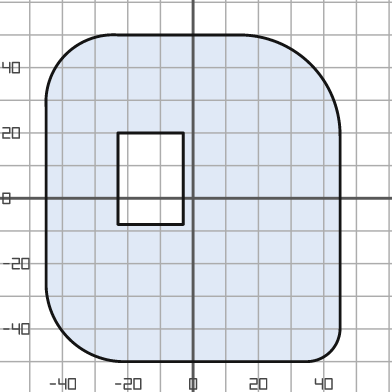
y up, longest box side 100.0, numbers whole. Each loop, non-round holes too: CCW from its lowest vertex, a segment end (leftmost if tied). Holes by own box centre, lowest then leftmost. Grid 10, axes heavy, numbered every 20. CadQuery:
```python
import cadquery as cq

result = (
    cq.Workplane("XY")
    .moveTo(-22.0, -50.0)
    .lineTo(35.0, -50.0)
    .threePointArc((42.0, -47.0), (45.0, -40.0))
    .lineTo(45.0, 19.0)
    .threePointArc((36.0, 41.0), (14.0, 50.0))
    .lineTo(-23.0, 50.0)
    .threePointArc((-39.0, 44.0), (-45.0, 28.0))
    .lineTo(-45.0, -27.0)
    .threePointArc((-38.0, -43.0), (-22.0, -50.0))
    .close()
    .moveTo(-23.0, -8.0)
    .lineTo(-3.0, -8.0)
    .lineTo(-3.0, 20.0)
    .lineTo(-23.0, 20.0)
    .close()
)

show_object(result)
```